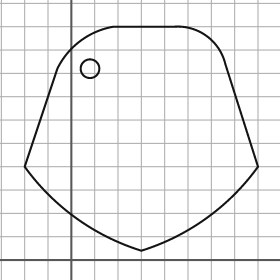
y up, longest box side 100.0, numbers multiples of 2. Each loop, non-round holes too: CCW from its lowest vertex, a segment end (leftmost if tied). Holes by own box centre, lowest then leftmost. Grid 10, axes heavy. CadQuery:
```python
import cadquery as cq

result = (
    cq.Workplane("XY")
    .moveTo(30.0, 4.0)
    .threePointArc((58.0, 18.0), (80.0, 40.0))
    .lineTo(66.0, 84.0)
    .threePointArc((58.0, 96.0), (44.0, 100.0))
    .lineTo(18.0, 100.0)
    .threePointArc((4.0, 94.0), (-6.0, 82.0))
    .lineTo(-20.0, 40.0)
    .threePointArc((2.0, 18.0), (30.0, 4.0))
    .close()
    .moveTo(8.0, 82.0)
    .circle(4.0)
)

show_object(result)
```